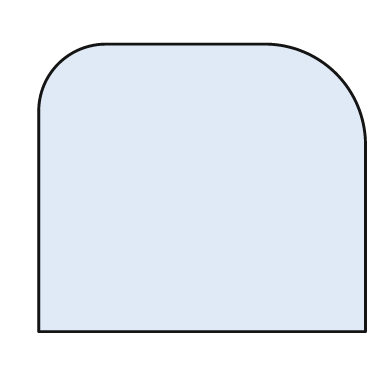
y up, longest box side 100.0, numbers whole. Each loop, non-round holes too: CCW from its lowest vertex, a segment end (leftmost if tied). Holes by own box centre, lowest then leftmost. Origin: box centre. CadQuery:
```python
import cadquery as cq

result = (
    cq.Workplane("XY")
    .moveTo(-50.0, -44.0)
    .lineTo(50.0, -44.0)
    .lineTo(50.0, 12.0)
    .threePointArc((41.0, 35.0), (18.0, 44.0))
    .lineTo(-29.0, 44.0)
    .threePointArc((-44.0, 38.0), (-50.0, 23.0))
    .close()
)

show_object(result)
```